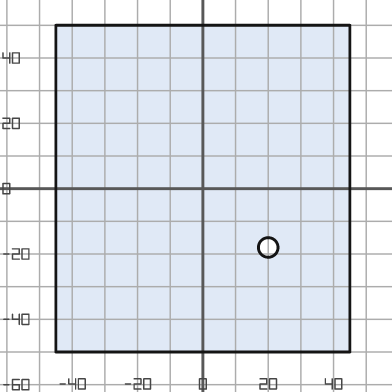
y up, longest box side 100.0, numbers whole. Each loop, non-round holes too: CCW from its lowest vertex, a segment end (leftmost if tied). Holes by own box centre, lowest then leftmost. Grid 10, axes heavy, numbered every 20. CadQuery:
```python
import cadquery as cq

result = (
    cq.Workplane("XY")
    .moveTo(-45.0, -50.0)
    .lineTo(45.0, -50.0)
    .lineTo(45.0, 50.0)
    .lineTo(-45.0, 50.0)
    .close()
    .moveTo(20.0, -18.0)
    .circle(3.0)
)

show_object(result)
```